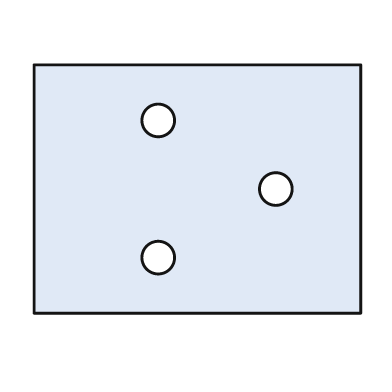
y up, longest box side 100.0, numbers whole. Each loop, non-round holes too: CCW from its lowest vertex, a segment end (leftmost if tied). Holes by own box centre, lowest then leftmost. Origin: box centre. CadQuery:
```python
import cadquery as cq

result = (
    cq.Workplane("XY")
    .moveTo(-50.0, -38.0)
    .lineTo(50.0, -38.0)
    .lineTo(50.0, 38.0)
    .lineTo(-50.0, 38.0)
    .close()
    .moveTo(-12.0, -21.0)
    .circle(5.0)
    .moveTo(24.0, 0.0)
    .circle(5.0)
    .moveTo(-12.0, 21.0)
    .circle(5.0)
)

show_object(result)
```